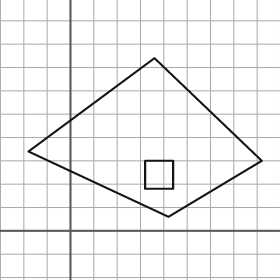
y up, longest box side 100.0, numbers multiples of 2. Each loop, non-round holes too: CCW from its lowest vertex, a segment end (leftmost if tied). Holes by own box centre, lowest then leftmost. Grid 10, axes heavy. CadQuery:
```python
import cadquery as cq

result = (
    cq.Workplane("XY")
    .moveTo(42.0, 6.0)
    .lineTo(82.0, 30.0)
    .lineTo(36.0, 74.0)
    .lineTo(-18.0, 34.0)
    .close()
    .moveTo(32.0, 18.0)
    .lineTo(44.0, 18.0)
    .lineTo(44.0, 30.0)
    .lineTo(32.0, 30.0)
    .close()
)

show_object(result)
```